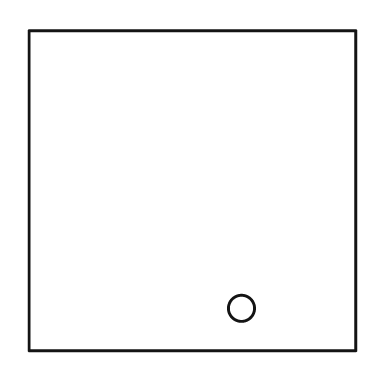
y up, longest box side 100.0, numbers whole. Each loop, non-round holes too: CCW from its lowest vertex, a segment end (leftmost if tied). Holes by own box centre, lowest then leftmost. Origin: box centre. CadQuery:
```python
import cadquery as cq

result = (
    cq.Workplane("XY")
    .moveTo(-50.0, -49.0)
    .lineTo(50.0, -49.0)
    .lineTo(50.0, 49.0)
    .lineTo(-50.0, 49.0)
    .close()
    .moveTo(15.0, -36.0)
    .circle(4.0)
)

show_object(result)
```